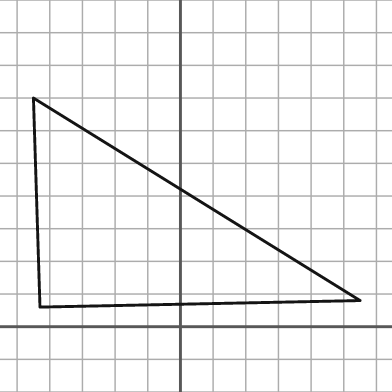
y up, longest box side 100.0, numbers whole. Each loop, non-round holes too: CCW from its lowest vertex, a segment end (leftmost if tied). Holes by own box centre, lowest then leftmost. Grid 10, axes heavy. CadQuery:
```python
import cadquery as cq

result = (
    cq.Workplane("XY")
    .moveTo(-43.0, 6.0)
    .lineTo(55.0, 8.0)
    .lineTo(-45.0, 70.0)
    .close()
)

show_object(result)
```